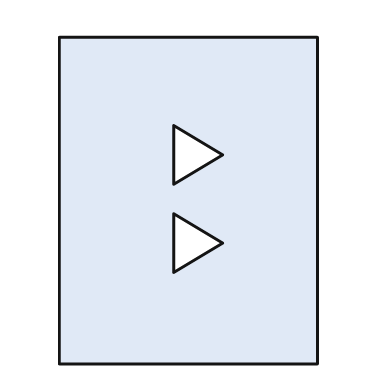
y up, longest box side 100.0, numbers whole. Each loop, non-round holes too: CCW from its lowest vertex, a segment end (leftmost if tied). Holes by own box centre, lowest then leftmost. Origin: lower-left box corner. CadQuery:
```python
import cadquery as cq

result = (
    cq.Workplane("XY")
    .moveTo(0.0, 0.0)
    .lineTo(79.0, 0.0)
    .lineTo(79.0, 100.0)
    .lineTo(0.0, 100.0)
    .close()
    .moveTo(35.0, 28.0)
    .lineTo(50.0, 37.0)
    .lineTo(35.0, 46.0)
    .close()
    .moveTo(35.0, 55.0)
    .lineTo(50.0, 64.0)
    .lineTo(35.0, 73.0)
    .close()
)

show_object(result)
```